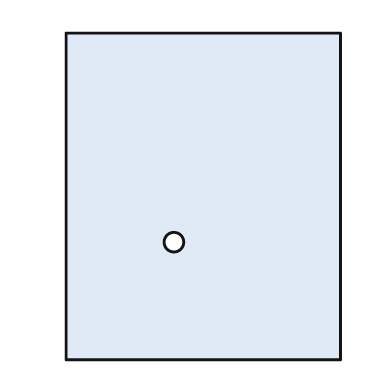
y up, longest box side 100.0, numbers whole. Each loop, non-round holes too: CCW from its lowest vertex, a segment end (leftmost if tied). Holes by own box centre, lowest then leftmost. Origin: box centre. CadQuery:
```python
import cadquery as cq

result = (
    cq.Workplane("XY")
    .moveTo(-42.0, -50.0)
    .lineTo(42.0, -50.0)
    .lineTo(42.0, 50.0)
    .lineTo(-42.0, 50.0)
    .close()
    .moveTo(-9.0, -14.0)
    .circle(3.0)
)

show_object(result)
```